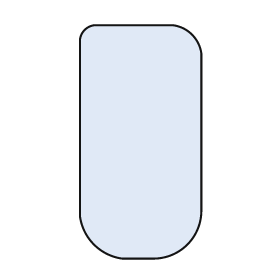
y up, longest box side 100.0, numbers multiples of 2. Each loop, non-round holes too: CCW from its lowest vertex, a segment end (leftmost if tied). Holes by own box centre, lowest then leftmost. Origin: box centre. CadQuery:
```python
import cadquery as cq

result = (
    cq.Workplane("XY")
    .moveTo(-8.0, -50.0)
    .lineTo(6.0, -50.0)
    .threePointArc((20.0, -44.0), (26.0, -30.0))
    .lineTo(26.0, 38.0)
    .threePointArc((22.0, 46.0), (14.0, 50.0))
    .lineTo(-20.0, 50.0)
    .threePointArc((-24.0, 48.0), (-26.0, 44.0))
    .lineTo(-26.0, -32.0)
    .threePointArc((-20.0, -44.0), (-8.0, -50.0))
    .close()
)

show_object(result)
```